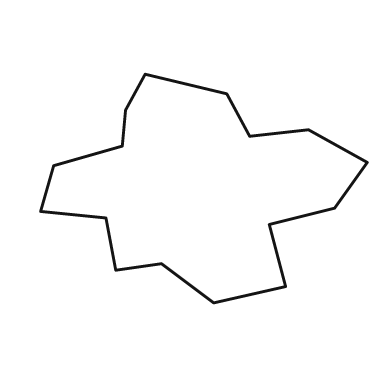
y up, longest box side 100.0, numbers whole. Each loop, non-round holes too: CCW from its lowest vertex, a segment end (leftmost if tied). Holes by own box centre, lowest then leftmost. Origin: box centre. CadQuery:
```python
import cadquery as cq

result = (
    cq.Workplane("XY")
    .moveTo(3.0, -35.0)
    .lineTo(25.0, -30.0)
    .lineTo(20.0, -11.0)
    .lineTo(40.0, -6.0)
    .lineTo(50.0, 8.0)
    .lineTo(32.0, 18.0)
    .lineTo(14.0, 16.0)
    .lineTo(7.0, 29.0)
    .lineTo(-18.0, 35.0)
    .lineTo(-24.0, 24.0)
    .lineTo(-25.0, 13.0)
    .lineTo(-46.0, 7.0)
    .lineTo(-50.0, -7.0)
    .lineTo(-30.0, -9.0)
    .lineTo(-27.0, -25.0)
    .lineTo(-13.0, -23.0)
    .close()
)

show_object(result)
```